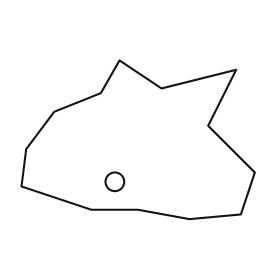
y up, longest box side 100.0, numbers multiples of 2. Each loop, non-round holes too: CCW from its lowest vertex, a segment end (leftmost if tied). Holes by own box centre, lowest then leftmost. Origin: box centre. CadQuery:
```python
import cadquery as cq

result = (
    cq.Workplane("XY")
    .moveTo(22.0, -34.0)
    .lineTo(44.0, -32.0)
    .lineTo(50.0, -14.0)
    .lineTo(30.0, 6.0)
    .lineTo(42.0, 30.0)
    .lineTo(10.0, 22.0)
    .lineTo(-8.0, 34.0)
    .lineTo(-16.0, 20.0)
    .lineTo(-36.0, 12.0)
    .lineTo(-48.0, -4.0)
    .lineTo(-50.0, -20.0)
    .lineTo(-20.0, -30.0)
    .lineTo(0.0, -30.0)
    .close()
    .moveTo(-10.0, -18.0)
    .circle(4.0)
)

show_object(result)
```